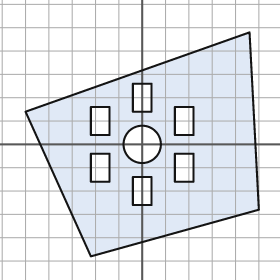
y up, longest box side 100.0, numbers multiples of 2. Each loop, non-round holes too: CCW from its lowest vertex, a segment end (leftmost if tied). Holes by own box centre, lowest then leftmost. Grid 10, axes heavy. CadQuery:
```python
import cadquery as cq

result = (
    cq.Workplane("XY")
    .moveTo(-22.0, -48.0)
    .lineTo(50.0, -28.0)
    .lineTo(46.0, 48.0)
    .lineTo(-50.0, 14.0)
    .close()
    .moveTo(-4.0, -26.0)
    .lineTo(4.0, -26.0)
    .lineTo(4.0, -14.0)
    .lineTo(-4.0, -14.0)
    .close()
    .moveTo(-22.0, -16.0)
    .lineTo(-14.0, -16.0)
    .lineTo(-14.0, -4.0)
    .lineTo(-22.0, -4.0)
    .close()
    .moveTo(14.0, -16.0)
    .lineTo(22.0, -16.0)
    .lineTo(22.0, -4.0)
    .lineTo(14.0, -4.0)
    .close()
    .moveTo(0.0, 0.0)
    .circle(8.0)
    .moveTo(-22.0, 4.0)
    .lineTo(-14.0, 4.0)
    .lineTo(-14.0, 16.0)
    .lineTo(-22.0, 16.0)
    .close()
    .moveTo(14.0, 4.0)
    .lineTo(22.0, 4.0)
    .lineTo(22.0, 16.0)
    .lineTo(14.0, 16.0)
    .close()
    .moveTo(-4.0, 14.0)
    .lineTo(4.0, 14.0)
    .lineTo(4.0, 26.0)
    .lineTo(-4.0, 26.0)
    .close()
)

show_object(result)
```